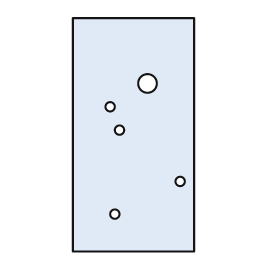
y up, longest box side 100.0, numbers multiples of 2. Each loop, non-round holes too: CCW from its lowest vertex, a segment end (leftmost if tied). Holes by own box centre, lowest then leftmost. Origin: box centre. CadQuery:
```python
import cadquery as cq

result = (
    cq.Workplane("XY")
    .moveTo(-26.0, -50.0)
    .lineTo(26.0, -50.0)
    .lineTo(26.0, 50.0)
    .lineTo(-26.0, 50.0)
    .close()
    .moveTo(-8.0, -34.0)
    .circle(2.0)
    .moveTo(20.0, -20.0)
    .circle(2.0)
    .moveTo(-6.0, 2.0)
    .circle(2.0)
    .moveTo(-10.0, 12.0)
    .circle(2.0)
    .moveTo(6.0, 22.0)
    .circle(4.0)
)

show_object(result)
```